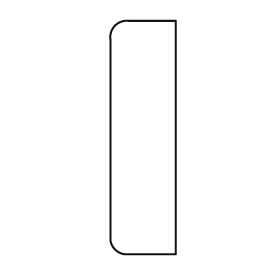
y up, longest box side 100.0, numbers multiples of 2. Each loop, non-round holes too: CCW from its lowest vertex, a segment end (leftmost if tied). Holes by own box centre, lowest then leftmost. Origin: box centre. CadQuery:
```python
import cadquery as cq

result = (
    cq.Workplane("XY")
    .moveTo(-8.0, -50.0)
    .lineTo(14.0, -50.0)
    .lineTo(14.0, 50.0)
    .lineTo(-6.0, 50.0)
    .threePointArc((-12.0, 48.0), (-14.0, 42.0))
    .lineTo(-14.0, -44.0)
    .threePointArc((-12.0, -48.0), (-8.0, -50.0))
    .close()
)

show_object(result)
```